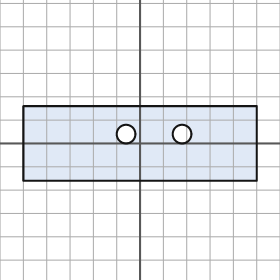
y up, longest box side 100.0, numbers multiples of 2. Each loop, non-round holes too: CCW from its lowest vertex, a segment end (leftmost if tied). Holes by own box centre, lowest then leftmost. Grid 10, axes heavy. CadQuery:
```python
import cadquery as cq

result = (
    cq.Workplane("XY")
    .moveTo(-50.0, -16.0)
    .lineTo(50.0, -16.0)
    .lineTo(50.0, 16.0)
    .lineTo(-50.0, 16.0)
    .close()
    .moveTo(-6.0, 4.0)
    .circle(4.0)
    .moveTo(18.0, 4.0)
    .circle(4.0)
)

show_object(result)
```